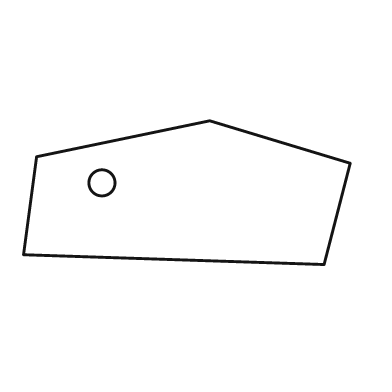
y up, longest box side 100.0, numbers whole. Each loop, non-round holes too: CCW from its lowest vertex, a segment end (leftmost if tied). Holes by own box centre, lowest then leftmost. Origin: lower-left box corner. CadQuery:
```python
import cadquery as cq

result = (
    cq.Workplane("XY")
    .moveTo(92.0, 0.0)
    .lineTo(100.0, 31.0)
    .lineTo(57.0, 44.0)
    .lineTo(4.0, 33.0)
    .lineTo(0.0, 3.0)
    .close()
    .moveTo(24.0, 25.0)
    .circle(4.0)
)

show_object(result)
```